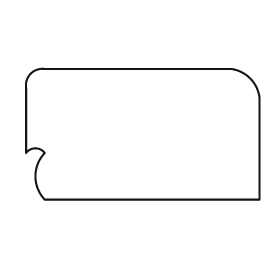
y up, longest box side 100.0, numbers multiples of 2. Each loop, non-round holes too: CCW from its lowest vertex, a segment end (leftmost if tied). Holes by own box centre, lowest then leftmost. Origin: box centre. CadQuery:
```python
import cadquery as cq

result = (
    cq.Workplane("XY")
    .moveTo(-42.0, -28.0)
    .lineTo(50.0, -28.0)
    .lineTo(50.0, 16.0)
    .threePointArc((46.0, 24.0), (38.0, 28.0))
    .lineTo(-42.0, 28.0)
    .threePointArc((-48.0, 26.0), (-50.0, 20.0))
    .lineTo(-50.0, -8.0)
    .threePointArc((-46.0, -6.0), (-42.0, -8.0))
    .threePointArc((-46.0, -18.0), (-42.0, -28.0))
    .close()
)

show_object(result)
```